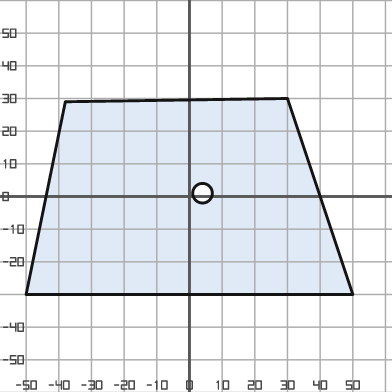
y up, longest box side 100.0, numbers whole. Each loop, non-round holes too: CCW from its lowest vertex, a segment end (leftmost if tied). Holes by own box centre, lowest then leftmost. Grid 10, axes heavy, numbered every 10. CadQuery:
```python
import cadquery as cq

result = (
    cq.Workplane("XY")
    .moveTo(-50.0, -30.0)
    .lineTo(50.0, -30.0)
    .lineTo(30.0, 30.0)
    .lineTo(-38.0, 29.0)
    .close()
    .moveTo(4.0, 1.0)
    .circle(3.0)
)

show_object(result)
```